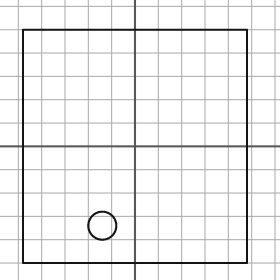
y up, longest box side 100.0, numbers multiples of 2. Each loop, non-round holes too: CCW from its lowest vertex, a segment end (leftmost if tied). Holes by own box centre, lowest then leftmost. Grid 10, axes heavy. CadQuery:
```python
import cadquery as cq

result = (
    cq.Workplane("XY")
    .moveTo(-48.0, -50.0)
    .lineTo(48.0, -50.0)
    .lineTo(48.0, 50.0)
    .lineTo(-48.0, 50.0)
    .close()
    .moveTo(-14.0, -34.0)
    .circle(6.0)
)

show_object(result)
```